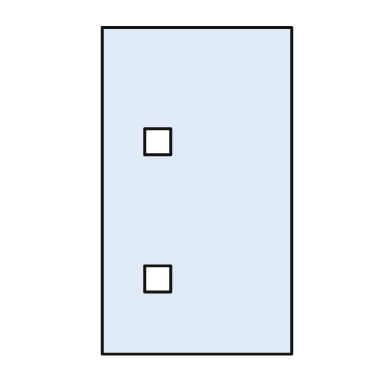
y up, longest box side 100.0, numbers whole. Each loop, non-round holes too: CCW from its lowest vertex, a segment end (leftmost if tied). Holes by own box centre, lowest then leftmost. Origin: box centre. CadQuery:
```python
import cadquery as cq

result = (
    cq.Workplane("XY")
    .moveTo(-29.0, -50.0)
    .lineTo(29.0, -50.0)
    .lineTo(29.0, 50.0)
    .lineTo(-29.0, 50.0)
    .close()
    .moveTo(-16.0, -31.0)
    .lineTo(-8.0, -31.0)
    .lineTo(-8.0, -23.0)
    .lineTo(-16.0, -23.0)
    .close()
    .moveTo(-16.0, 11.0)
    .lineTo(-8.0, 11.0)
    .lineTo(-8.0, 19.0)
    .lineTo(-16.0, 19.0)
    .close()
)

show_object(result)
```